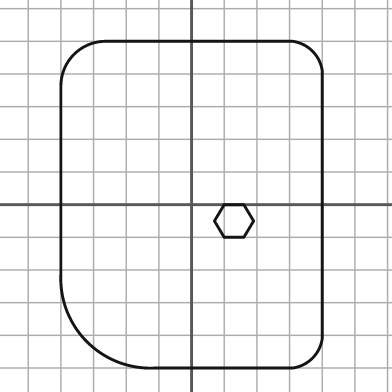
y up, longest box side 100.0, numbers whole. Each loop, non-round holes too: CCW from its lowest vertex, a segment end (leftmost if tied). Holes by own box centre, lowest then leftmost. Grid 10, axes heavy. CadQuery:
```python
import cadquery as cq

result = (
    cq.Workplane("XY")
    .moveTo(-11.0, -50.0)
    .lineTo(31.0, -50.0)
    .threePointArc((37.0, -47.0), (40.0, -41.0))
    .lineTo(40.0, 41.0)
    .threePointArc((37.0, 47.0), (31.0, 50.0))
    .lineTo(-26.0, 50.0)
    .threePointArc((-36.0, 46.0), (-40.0, 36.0))
    .lineTo(-40.0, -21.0)
    .threePointArc((-32.0, -42.0), (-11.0, -50.0))
    .close()
    .moveTo(10.0, -10.0)
    .lineTo(16.0, -10.0)
    .lineTo(19.0, -5.0)
    .lineTo(16.0, 0.0)
    .lineTo(10.0, 0.0)
    .lineTo(7.0, -5.0)
    .close()
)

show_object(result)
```